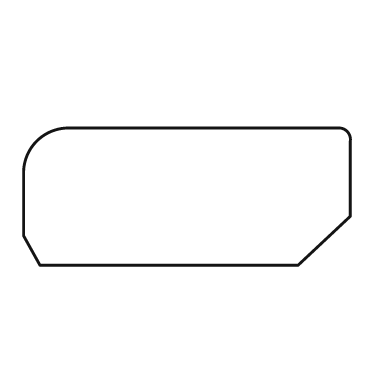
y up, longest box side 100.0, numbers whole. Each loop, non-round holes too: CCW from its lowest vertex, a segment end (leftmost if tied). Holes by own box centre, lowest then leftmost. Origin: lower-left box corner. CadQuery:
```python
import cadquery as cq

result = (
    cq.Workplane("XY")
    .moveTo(5.0, 0.0)
    .lineTo(84.0, 0.0)
    .lineTo(100.0, 15.0)
    .lineTo(100.0, 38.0)
    .threePointArc((99.0, 41.0), (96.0, 42.0))
    .lineTo(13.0, 42.0)
    .threePointArc((4.0, 38.0), (0.0, 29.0))
    .lineTo(0.0, 9.0)
    .close()
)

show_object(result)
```